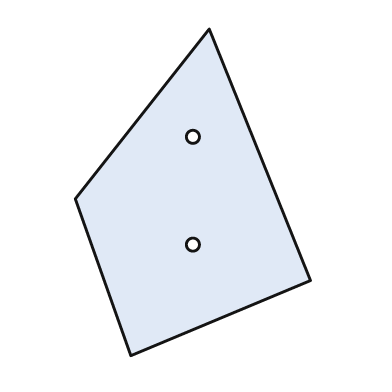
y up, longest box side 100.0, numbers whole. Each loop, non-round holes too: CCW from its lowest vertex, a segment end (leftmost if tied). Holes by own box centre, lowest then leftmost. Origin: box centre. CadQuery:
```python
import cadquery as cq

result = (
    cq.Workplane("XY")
    .moveTo(-19.0, -50.0)
    .lineTo(36.0, -27.0)
    .lineTo(5.0, 50.0)
    .lineTo(-36.0, -2.0)
    .close()
    .moveTo(0.0, -16.0)
    .circle(2.0)
    .moveTo(0.0, 17.0)
    .circle(2.0)
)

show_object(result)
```